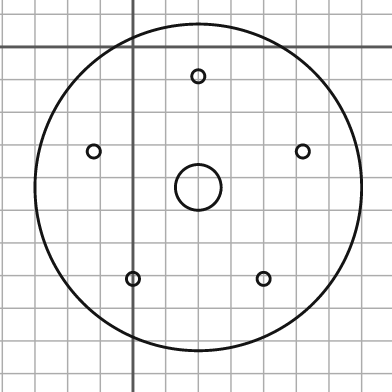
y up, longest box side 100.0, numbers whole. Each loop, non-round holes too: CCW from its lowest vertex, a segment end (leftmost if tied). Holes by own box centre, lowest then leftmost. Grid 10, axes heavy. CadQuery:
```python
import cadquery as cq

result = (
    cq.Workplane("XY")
    .moveTo(20.0, -43.0)
    .circle(50.0)
    .moveTo(0.0, -71.0)
    .circle(2.0)
    .moveTo(40.0, -71.0)
    .circle(2.0)
    .moveTo(20.0, -43.0)
    .circle(7.0)
    .moveTo(-12.0, -32.0)
    .circle(2.0)
    .moveTo(52.0, -32.0)
    .circle(2.0)
    .moveTo(20.0, -9.0)
    .circle(2.0)
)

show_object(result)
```